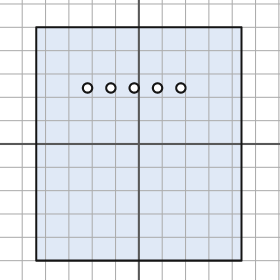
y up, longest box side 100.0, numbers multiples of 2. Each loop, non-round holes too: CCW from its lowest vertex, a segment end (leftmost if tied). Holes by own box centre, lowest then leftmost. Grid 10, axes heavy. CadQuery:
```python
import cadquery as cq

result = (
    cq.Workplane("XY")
    .moveTo(-44.0, -50.0)
    .lineTo(44.0, -50.0)
    .lineTo(44.0, 50.0)
    .lineTo(-44.0, 50.0)
    .close()
    .moveTo(-22.0, 24.0)
    .circle(2.0)
    .moveTo(-12.0, 24.0)
    .circle(2.0)
    .moveTo(-2.0, 24.0)
    .circle(2.0)
    .moveTo(8.0, 24.0)
    .circle(2.0)
    .moveTo(18.0, 24.0)
    .circle(2.0)
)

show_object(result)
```